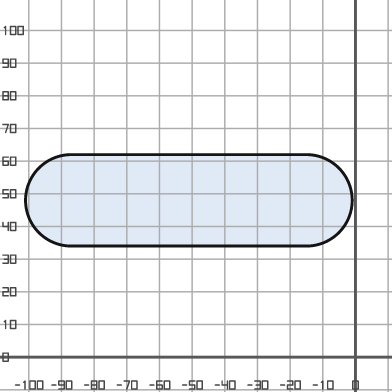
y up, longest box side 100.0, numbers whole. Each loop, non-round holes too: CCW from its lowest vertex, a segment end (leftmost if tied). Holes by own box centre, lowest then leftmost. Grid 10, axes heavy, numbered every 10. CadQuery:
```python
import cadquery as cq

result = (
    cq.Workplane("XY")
    .moveTo(-87.0, 34.0)
    .lineTo(-15.0, 34.0)
    .threePointArc((-1.0, 48.0), (-15.0, 62.0))
    .lineTo(-87.0, 62.0)
    .threePointArc((-101.0, 48.0), (-87.0, 34.0))
    .close()
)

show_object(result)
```